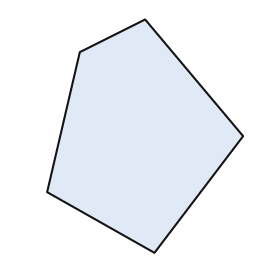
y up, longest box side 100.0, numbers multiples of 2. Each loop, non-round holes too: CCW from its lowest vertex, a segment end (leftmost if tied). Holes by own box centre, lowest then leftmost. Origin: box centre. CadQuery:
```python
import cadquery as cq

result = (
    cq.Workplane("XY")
    .moveTo(4.0, -50.0)
    .lineTo(42.0, 0.0)
    .lineTo(0.0, 50.0)
    .lineTo(-28.0, 36.0)
    .lineTo(-42.0, -24.0)
    .close()
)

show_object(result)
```